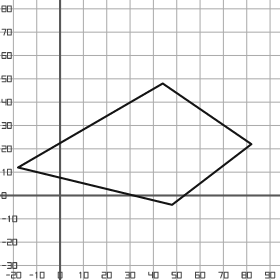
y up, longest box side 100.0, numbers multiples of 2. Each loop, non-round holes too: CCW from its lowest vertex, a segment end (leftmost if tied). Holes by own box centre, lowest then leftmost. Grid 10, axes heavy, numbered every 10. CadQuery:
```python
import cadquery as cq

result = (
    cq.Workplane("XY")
    .moveTo(48.0, -4.0)
    .lineTo(82.0, 22.0)
    .lineTo(44.0, 48.0)
    .lineTo(-18.0, 12.0)
    .close()
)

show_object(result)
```